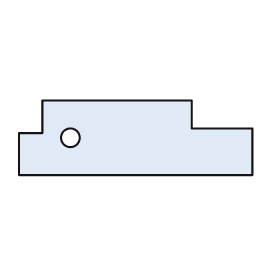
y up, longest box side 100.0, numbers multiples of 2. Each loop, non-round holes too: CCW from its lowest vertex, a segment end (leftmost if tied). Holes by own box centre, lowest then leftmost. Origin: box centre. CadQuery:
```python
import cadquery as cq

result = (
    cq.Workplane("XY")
    .moveTo(-50.0, -16.0)
    .lineTo(50.0, -16.0)
    .lineTo(50.0, 4.0)
    .lineTo(24.0, 4.0)
    .lineTo(24.0, 16.0)
    .lineTo(-40.0, 16.0)
    .lineTo(-40.0, 2.0)
    .lineTo(-50.0, 2.0)
    .close()
    .moveTo(-28.0, 0.0)
    .circle(4.0)
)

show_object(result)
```